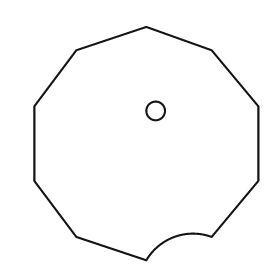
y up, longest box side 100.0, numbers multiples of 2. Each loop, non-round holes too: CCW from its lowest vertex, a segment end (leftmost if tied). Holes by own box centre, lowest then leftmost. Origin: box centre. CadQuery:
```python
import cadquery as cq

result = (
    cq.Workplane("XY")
    .moveTo(0.0, -50.0)
    .threePointArc((12.0, -40.0), (28.0, -40.0))
    .lineTo(48.0, -16.0)
    .lineTo(48.0, 16.0)
    .lineTo(28.0, 40.0)
    .lineTo(0.0, 50.0)
    .lineTo(-30.0, 40.0)
    .lineTo(-48.0, 16.0)
    .lineTo(-48.0, -16.0)
    .lineTo(-30.0, -40.0)
    .close()
    .moveTo(4.0, 14.0)
    .circle(4.0)
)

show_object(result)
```